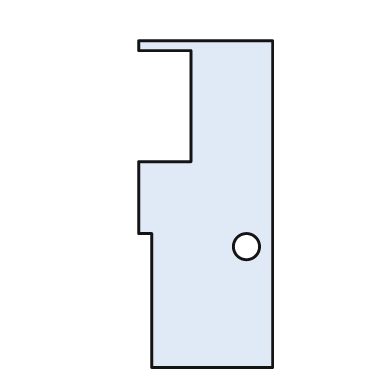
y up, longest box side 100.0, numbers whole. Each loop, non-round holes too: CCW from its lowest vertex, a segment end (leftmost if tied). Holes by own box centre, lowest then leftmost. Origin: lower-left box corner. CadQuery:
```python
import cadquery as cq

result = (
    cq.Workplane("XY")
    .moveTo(4.0, 0.0)
    .lineTo(41.0, 0.0)
    .lineTo(41.0, 100.0)
    .lineTo(0.0, 100.0)
    .lineTo(0.0, 97.0)
    .lineTo(16.0, 97.0)
    .lineTo(16.0, 63.0)
    .lineTo(0.0, 63.0)
    .lineTo(0.0, 41.0)
    .lineTo(4.0, 41.0)
    .close()
    .moveTo(33.0, 37.0)
    .circle(4.0)
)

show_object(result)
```